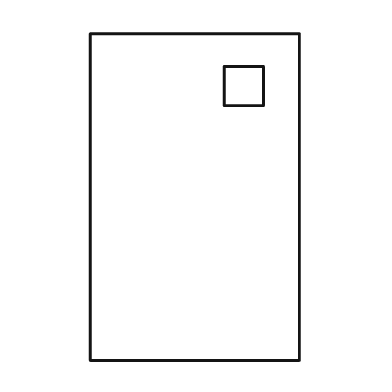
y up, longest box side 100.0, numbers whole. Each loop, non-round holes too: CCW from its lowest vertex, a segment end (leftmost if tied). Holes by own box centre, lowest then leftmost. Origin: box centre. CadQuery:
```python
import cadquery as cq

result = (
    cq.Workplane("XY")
    .moveTo(-32.0, -50.0)
    .lineTo(32.0, -50.0)
    .lineTo(32.0, 50.0)
    .lineTo(-32.0, 50.0)
    .close()
    .moveTo(9.0, 28.0)
    .lineTo(21.0, 28.0)
    .lineTo(21.0, 40.0)
    .lineTo(9.0, 40.0)
    .close()
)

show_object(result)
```